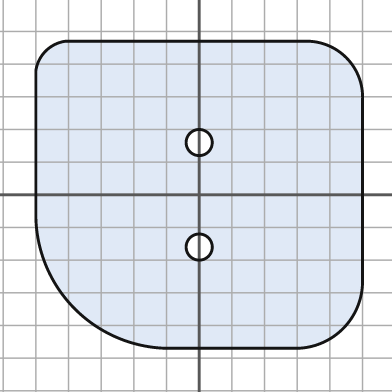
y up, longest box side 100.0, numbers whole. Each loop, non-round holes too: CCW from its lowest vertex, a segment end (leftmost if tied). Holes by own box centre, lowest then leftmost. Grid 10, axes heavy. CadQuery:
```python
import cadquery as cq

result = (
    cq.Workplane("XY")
    .moveTo(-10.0, -47.0)
    .lineTo(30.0, -47.0)
    .threePointArc((44.0, -41.0), (50.0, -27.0))
    .lineTo(50.0, 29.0)
    .threePointArc((45.0, 42.0), (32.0, 47.0))
    .lineTo(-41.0, 47.0)
    .threePointArc((-47.0, 44.0), (-50.0, 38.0))
    .lineTo(-50.0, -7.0)
    .threePointArc((-38.0, -35.0), (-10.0, -47.0))
    .close()
    .moveTo(0.0, -16.0)
    .circle(4.0)
    .moveTo(0.0, 16.0)
    .circle(4.0)
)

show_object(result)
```